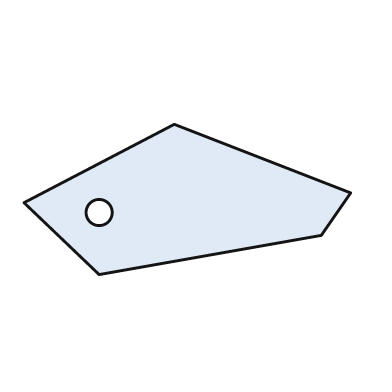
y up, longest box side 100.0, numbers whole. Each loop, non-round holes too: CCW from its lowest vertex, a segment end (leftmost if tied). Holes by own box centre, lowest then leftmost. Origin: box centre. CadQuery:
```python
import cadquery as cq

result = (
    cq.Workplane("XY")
    .moveTo(-27.0, -23.0)
    .lineTo(41.0, -11.0)
    .lineTo(50.0, 2.0)
    .lineTo(-4.0, 23.0)
    .lineTo(-50.0, -1.0)
    .close()
    .moveTo(-27.0, -4.0)
    .circle(4.0)
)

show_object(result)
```